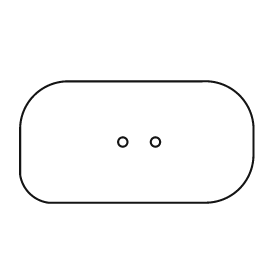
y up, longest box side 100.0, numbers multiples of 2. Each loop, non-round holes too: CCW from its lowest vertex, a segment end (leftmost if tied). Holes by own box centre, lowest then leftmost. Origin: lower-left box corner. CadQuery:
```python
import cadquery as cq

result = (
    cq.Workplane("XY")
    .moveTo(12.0, 0.0)
    .lineTo(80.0, 0.0)
    .threePointArc((94.0, 6.0), (100.0, 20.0))
    .lineTo(100.0, 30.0)
    .threePointArc((94.0, 46.0), (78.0, 52.0))
    .lineTo(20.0, 52.0)
    .threePointArc((6.0, 46.0), (0.0, 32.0))
    .lineTo(0.0, 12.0)
    .threePointArc((4.0, 4.0), (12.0, 0.0))
    .close()
    .moveTo(44.0, 26.0)
    .circle(2.0)
    .moveTo(58.0, 26.0)
    .circle(2.0)
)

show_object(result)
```